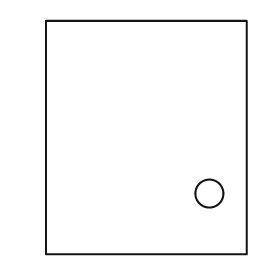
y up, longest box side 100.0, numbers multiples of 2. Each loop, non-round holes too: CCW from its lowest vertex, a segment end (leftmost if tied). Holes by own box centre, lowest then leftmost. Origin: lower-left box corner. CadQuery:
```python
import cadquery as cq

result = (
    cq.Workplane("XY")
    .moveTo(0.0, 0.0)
    .lineTo(86.0, 0.0)
    .lineTo(86.0, 100.0)
    .lineTo(0.0, 100.0)
    .close()
    .moveTo(70.0, 26.0)
    .circle(6.0)
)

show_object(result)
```